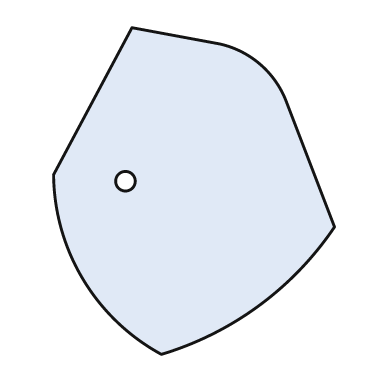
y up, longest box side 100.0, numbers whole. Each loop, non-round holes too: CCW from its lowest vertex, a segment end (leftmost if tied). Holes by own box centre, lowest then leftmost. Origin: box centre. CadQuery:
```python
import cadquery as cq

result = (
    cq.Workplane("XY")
    .moveTo(-10.0, -50.0)
    .threePointArc((20.0, -35.0), (43.0, -11.0))
    .lineTo(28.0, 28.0)
    .threePointArc((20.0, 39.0), (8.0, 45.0))
    .lineTo(-19.0, 50.0)
    .lineTo(-43.0, 5.0)
    .threePointArc((-34.0, -27.0), (-10.0, -50.0))
    .close()
    .moveTo(-21.0, 3.0)
    .circle(3.0)
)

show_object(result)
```